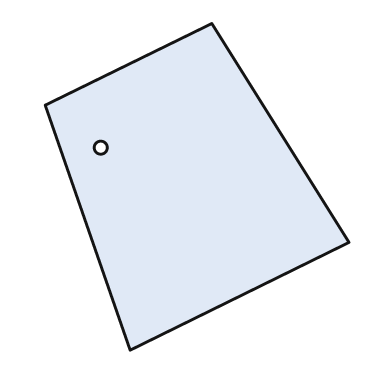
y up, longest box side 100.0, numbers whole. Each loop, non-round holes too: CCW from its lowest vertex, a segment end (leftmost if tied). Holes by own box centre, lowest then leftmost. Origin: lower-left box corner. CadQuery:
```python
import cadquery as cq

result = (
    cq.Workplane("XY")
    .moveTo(26.0, 0.0)
    .lineTo(93.0, 33.0)
    .lineTo(51.0, 100.0)
    .lineTo(0.0, 75.0)
    .close()
    .moveTo(17.0, 62.0)
    .circle(2.0)
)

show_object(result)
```